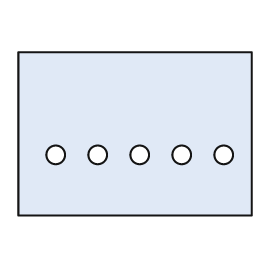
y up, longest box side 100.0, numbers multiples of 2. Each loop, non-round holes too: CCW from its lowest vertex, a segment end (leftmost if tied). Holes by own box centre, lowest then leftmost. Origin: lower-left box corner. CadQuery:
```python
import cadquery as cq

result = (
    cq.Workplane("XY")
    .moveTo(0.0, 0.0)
    .lineTo(100.0, 0.0)
    .lineTo(100.0, 70.0)
    .lineTo(0.0, 70.0)
    .close()
    .moveTo(16.0, 26.0)
    .circle(4.0)
    .moveTo(34.0, 26.0)
    .circle(4.0)
    .moveTo(52.0, 26.0)
    .circle(4.0)
    .moveTo(70.0, 26.0)
    .circle(4.0)
    .moveTo(88.0, 26.0)
    .circle(4.0)
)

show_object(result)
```